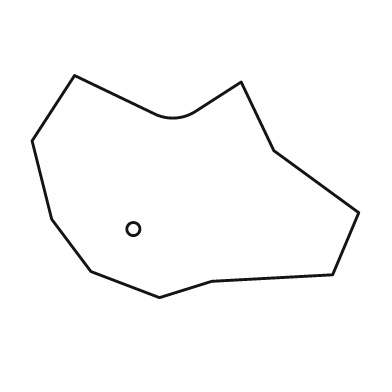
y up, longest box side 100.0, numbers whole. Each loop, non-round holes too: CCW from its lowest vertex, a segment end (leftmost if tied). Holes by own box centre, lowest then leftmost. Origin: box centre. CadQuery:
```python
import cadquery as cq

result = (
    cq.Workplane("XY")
    .moveTo(-11.0, -34.0)
    .lineTo(5.0, -29.0)
    .lineTo(42.0, -27.0)
    .lineTo(50.0, -8.0)
    .lineTo(24.0, 11.0)
    .lineTo(14.0, 32.0)
    .lineTo(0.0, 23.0)
    .threePointArc((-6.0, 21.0), (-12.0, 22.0))
    .lineTo(-37.0, 34.0)
    .lineTo(-50.0, 14.0)
    .lineTo(-44.0, -10.0)
    .lineTo(-32.0, -26.0)
    .close()
    .moveTo(-19.0, -13.0)
    .circle(2.0)
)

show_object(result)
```